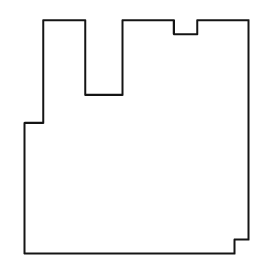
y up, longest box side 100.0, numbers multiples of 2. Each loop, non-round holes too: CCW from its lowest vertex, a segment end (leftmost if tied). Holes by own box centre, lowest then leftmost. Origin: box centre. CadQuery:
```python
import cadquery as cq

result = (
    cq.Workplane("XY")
    .moveTo(-48.0, -50.0)
    .lineTo(42.0, -50.0)
    .lineTo(42.0, -44.0)
    .lineTo(48.0, -44.0)
    .lineTo(48.0, 50.0)
    .lineTo(26.0, 50.0)
    .lineTo(26.0, 44.0)
    .lineTo(16.0, 44.0)
    .lineTo(16.0, 50.0)
    .lineTo(-6.0, 50.0)
    .lineTo(-6.0, 18.0)
    .lineTo(-22.0, 18.0)
    .lineTo(-22.0, 50.0)
    .lineTo(-40.0, 50.0)
    .lineTo(-40.0, 6.0)
    .lineTo(-48.0, 6.0)
    .close()
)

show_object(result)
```